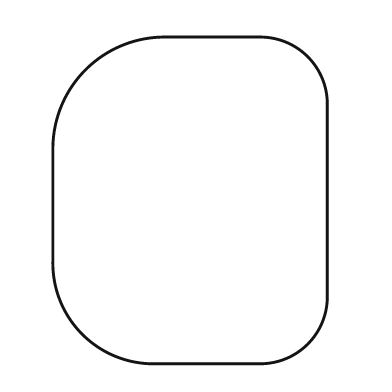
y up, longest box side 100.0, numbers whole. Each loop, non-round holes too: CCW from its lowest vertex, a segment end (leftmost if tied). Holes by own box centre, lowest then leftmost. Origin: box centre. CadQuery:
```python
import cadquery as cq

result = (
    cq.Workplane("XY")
    .moveTo(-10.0, -50.0)
    .lineTo(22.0, -50.0)
    .threePointArc((36.0, -44.0), (42.0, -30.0))
    .lineTo(42.0, 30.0)
    .threePointArc((36.0, 44.0), (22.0, 50.0))
    .lineTo(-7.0, 50.0)
    .threePointArc((-32.0, 40.0), (-42.0, 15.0))
    .lineTo(-42.0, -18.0)
    .threePointArc((-33.0, -41.0), (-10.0, -50.0))
    .close()
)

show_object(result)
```